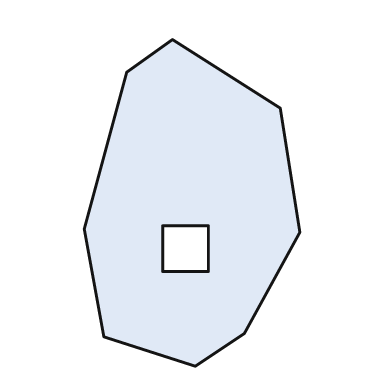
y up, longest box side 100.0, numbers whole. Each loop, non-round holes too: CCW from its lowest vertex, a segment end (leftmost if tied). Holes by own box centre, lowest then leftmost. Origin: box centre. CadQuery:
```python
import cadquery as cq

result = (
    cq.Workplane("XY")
    .moveTo(1.0, -50.0)
    .lineTo(16.0, -40.0)
    .lineTo(33.0, -9.0)
    .lineTo(27.0, 29.0)
    .lineTo(-6.0, 50.0)
    .lineTo(-20.0, 40.0)
    .lineTo(-33.0, -8.0)
    .lineTo(-27.0, -41.0)
    .close()
    .moveTo(-9.0, -21.0)
    .lineTo(5.0, -21.0)
    .lineTo(5.0, -7.0)
    .lineTo(-9.0, -7.0)
    .close()
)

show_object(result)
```